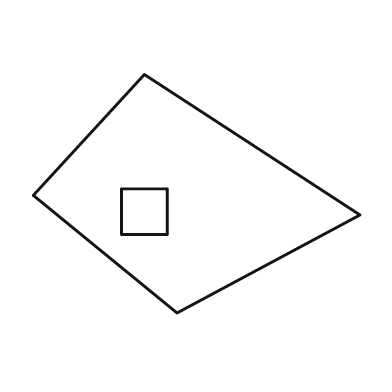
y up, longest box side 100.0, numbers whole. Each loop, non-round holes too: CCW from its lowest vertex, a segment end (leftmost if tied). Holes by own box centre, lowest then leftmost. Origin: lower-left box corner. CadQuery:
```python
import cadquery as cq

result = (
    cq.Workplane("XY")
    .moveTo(44.0, 0.0)
    .lineTo(100.0, 30.0)
    .lineTo(34.0, 73.0)
    .lineTo(0.0, 36.0)
    .close()
    .moveTo(27.0, 24.0)
    .lineTo(41.0, 24.0)
    .lineTo(41.0, 38.0)
    .lineTo(27.0, 38.0)
    .close()
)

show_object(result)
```